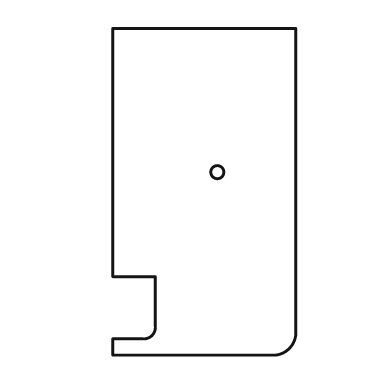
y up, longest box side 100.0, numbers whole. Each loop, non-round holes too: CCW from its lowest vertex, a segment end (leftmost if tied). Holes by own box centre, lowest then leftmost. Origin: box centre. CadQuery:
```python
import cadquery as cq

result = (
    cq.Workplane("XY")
    .moveTo(-28.0, -50.0)
    .lineTo(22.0, -50.0)
    .threePointArc((26.0, -48.0), (28.0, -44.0))
    .lineTo(28.0, 50.0)
    .lineTo(-28.0, 50.0)
    .lineTo(-28.0, -26.0)
    .lineTo(-15.0, -26.0)
    .lineTo(-15.0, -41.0)
    .threePointArc((-16.0, -44.0), (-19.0, -45.0))
    .lineTo(-28.0, -45.0)
    .close()
    .moveTo(4.0, 6.0)
    .circle(2.0)
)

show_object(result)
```